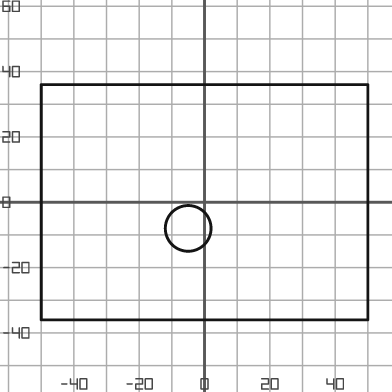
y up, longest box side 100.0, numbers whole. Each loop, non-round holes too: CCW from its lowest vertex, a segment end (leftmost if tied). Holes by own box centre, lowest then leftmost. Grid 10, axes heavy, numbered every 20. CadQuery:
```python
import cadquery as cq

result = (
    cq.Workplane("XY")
    .moveTo(-50.0, -36.0)
    .lineTo(50.0, -36.0)
    .lineTo(50.0, 36.0)
    .lineTo(-50.0, 36.0)
    .close()
    .moveTo(-5.0, -8.0)
    .circle(7.0)
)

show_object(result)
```